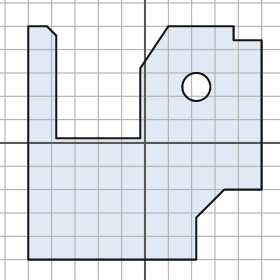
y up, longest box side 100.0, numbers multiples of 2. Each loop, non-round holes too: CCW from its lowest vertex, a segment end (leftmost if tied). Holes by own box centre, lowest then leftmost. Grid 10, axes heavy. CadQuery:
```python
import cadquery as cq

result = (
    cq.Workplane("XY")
    .moveTo(-50.0, -50.0)
    .lineTo(22.0, -50.0)
    .lineTo(22.0, -32.0)
    .lineTo(34.0, -20.0)
    .lineTo(50.0, -20.0)
    .lineTo(50.0, 44.0)
    .lineTo(38.0, 44.0)
    .lineTo(38.0, 50.0)
    .lineTo(10.0, 50.0)
    .lineTo(-2.0, 32.0)
    .lineTo(-2.0, 2.0)
    .lineTo(-38.0, 2.0)
    .lineTo(-38.0, 46.0)
    .lineTo(-42.0, 50.0)
    .lineTo(-50.0, 50.0)
    .close()
    .moveTo(22.0, 24.0)
    .circle(6.0)
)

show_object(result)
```